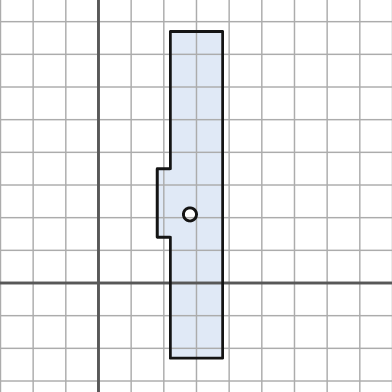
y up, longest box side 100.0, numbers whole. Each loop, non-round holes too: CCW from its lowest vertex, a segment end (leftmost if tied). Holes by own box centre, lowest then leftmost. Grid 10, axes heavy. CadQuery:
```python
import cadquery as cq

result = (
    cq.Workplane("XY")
    .moveTo(22.0, -23.0)
    .lineTo(38.0, -23.0)
    .lineTo(38.0, 77.0)
    .lineTo(22.0, 77.0)
    .lineTo(22.0, 35.0)
    .lineTo(18.0, 35.0)
    .lineTo(18.0, 14.0)
    .lineTo(22.0, 14.0)
    .close()
    .moveTo(28.0, 21.0)
    .circle(2.0)
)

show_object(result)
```